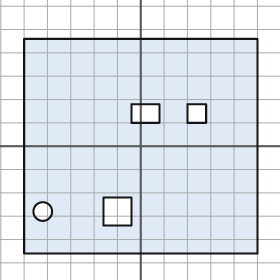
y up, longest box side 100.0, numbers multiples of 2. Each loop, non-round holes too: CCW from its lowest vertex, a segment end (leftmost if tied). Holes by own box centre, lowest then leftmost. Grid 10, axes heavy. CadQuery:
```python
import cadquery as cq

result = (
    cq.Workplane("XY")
    .moveTo(-50.0, -46.0)
    .lineTo(50.0, -46.0)
    .lineTo(50.0, 46.0)
    .lineTo(-50.0, 46.0)
    .close()
    .moveTo(-42.0, -28.0)
    .circle(4.0)
    .moveTo(-16.0, -34.0)
    .lineTo(-4.0, -34.0)
    .lineTo(-4.0, -22.0)
    .lineTo(-16.0, -22.0)
    .close()
    .moveTo(-4.0, 10.0)
    .lineTo(8.0, 10.0)
    .lineTo(8.0, 18.0)
    .lineTo(-4.0, 18.0)
    .close()
    .moveTo(20.0, 10.0)
    .lineTo(28.0, 10.0)
    .lineTo(28.0, 18.0)
    .lineTo(20.0, 18.0)
    .close()
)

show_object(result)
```